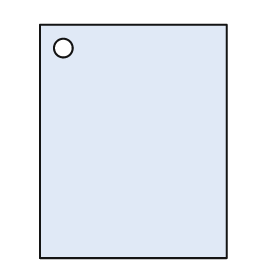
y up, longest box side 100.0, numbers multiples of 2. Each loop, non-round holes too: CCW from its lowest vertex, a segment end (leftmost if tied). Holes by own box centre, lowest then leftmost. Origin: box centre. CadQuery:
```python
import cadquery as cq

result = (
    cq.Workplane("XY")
    .moveTo(-40.0, -50.0)
    .lineTo(40.0, -50.0)
    .lineTo(40.0, 50.0)
    .lineTo(-40.0, 50.0)
    .close()
    .moveTo(-30.0, 40.0)
    .circle(4.0)
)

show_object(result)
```